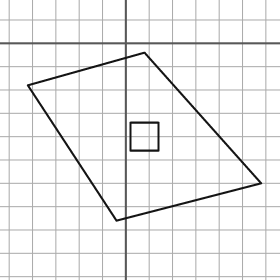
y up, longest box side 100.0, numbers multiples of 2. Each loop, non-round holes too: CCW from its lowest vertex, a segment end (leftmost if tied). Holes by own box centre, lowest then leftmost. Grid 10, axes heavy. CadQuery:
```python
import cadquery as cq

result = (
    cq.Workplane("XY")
    .moveTo(-4.0, -76.0)
    .lineTo(58.0, -60.0)
    .lineTo(8.0, -4.0)
    .lineTo(-42.0, -18.0)
    .close()
    .moveTo(2.0, -46.0)
    .lineTo(14.0, -46.0)
    .lineTo(14.0, -34.0)
    .lineTo(2.0, -34.0)
    .close()
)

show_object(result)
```